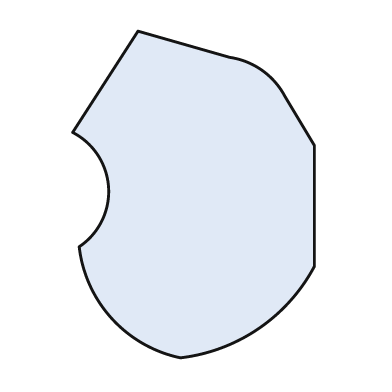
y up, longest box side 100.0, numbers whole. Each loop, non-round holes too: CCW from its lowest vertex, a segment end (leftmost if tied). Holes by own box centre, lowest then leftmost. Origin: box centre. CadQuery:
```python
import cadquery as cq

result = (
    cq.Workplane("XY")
    .moveTo(-4.0, -50.0)
    .threePointArc((20.0, -41.0), (37.0, -22.0))
    .lineTo(37.0, 15.0)
    .lineTo(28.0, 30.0)
    .threePointArc((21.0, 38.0), (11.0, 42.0))
    .lineTo(-17.0, 50.0)
    .lineTo(-37.0, 19.0)
    .threePointArc((-26.0, 2.0), (-35.0, -16.0))
    .threePointArc((-25.0, -38.0), (-4.0, -50.0))
    .close()
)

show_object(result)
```